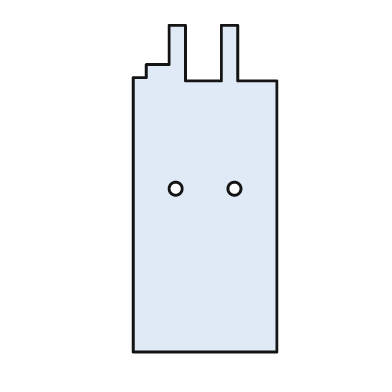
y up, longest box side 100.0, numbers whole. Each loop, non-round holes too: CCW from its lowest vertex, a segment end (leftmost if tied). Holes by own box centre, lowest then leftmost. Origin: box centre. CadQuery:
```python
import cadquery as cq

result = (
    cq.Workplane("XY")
    .moveTo(-22.0, -50.0)
    .lineTo(22.0, -50.0)
    .lineTo(22.0, 33.0)
    .lineTo(10.0, 33.0)
    .lineTo(10.0, 50.0)
    .lineTo(5.0, 50.0)
    .lineTo(5.0, 33.0)
    .lineTo(-6.0, 33.0)
    .lineTo(-6.0, 50.0)
    .lineTo(-11.0, 50.0)
    .lineTo(-11.0, 38.0)
    .lineTo(-18.0, 38.0)
    .lineTo(-18.0, 34.0)
    .lineTo(-22.0, 34.0)
    .close()
    .moveTo(-9.0, 0.0)
    .circle(2.0)
    .moveTo(9.0, 0.0)
    .circle(2.0)
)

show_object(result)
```